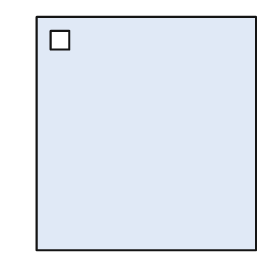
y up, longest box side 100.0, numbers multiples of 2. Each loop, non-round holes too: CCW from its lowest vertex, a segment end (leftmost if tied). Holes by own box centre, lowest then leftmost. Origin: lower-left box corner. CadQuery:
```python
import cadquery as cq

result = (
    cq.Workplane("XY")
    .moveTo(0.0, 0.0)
    .lineTo(94.0, 0.0)
    .lineTo(94.0, 100.0)
    .lineTo(0.0, 100.0)
    .close()
    .moveTo(6.0, 86.0)
    .lineTo(14.0, 86.0)
    .lineTo(14.0, 94.0)
    .lineTo(6.0, 94.0)
    .close()
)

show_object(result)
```